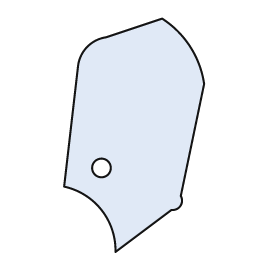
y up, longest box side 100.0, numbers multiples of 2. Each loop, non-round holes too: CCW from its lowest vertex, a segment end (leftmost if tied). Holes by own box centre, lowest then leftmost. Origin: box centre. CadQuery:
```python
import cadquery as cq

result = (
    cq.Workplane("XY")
    .moveTo(-8.0, -50.0)
    .lineTo(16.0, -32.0)
    .threePointArc((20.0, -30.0), (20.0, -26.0))
    .lineTo(30.0, 22.0)
    .threePointArc((24.0, 38.0), (12.0, 50.0))
    .lineTo(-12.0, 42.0)
    .threePointArc((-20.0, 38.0), (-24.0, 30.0))
    .lineTo(-30.0, -22.0)
    .threePointArc((-14.0, -32.0), (-8.0, -50.0))
    .close()
    .moveTo(-14.0, -14.0)
    .circle(4.0)
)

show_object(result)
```